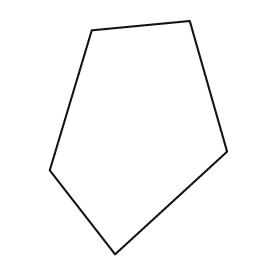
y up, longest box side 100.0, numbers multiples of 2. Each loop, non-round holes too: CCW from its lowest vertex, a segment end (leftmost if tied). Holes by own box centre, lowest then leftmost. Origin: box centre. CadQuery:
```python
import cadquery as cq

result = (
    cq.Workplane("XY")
    .moveTo(-10.0, -50.0)
    .lineTo(38.0, -6.0)
    .lineTo(22.0, 50.0)
    .lineTo(-20.0, 46.0)
    .lineTo(-38.0, -14.0)
    .close()
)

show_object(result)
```